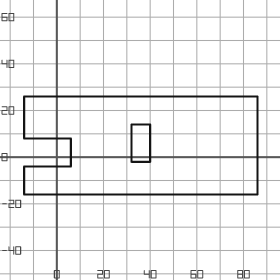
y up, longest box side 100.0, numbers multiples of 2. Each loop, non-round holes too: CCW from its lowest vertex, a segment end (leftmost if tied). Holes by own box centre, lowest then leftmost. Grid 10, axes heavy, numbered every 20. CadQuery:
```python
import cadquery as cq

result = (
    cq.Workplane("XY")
    .moveTo(-14.0, -16.0)
    .lineTo(86.0, -16.0)
    .lineTo(86.0, 26.0)
    .lineTo(-14.0, 26.0)
    .lineTo(-14.0, 8.0)
    .lineTo(6.0, 8.0)
    .lineTo(6.0, -4.0)
    .lineTo(-14.0, -4.0)
    .close()
    .moveTo(32.0, -2.0)
    .lineTo(40.0, -2.0)
    .lineTo(40.0, 14.0)
    .lineTo(32.0, 14.0)
    .close()
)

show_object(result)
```